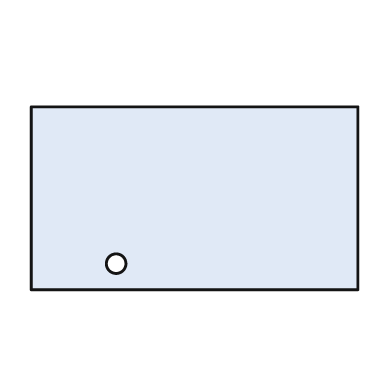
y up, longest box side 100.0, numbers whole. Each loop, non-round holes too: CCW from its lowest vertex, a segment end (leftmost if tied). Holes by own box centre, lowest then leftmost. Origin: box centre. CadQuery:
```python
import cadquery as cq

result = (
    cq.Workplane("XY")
    .moveTo(-50.0, -28.0)
    .lineTo(50.0, -28.0)
    .lineTo(50.0, 28.0)
    .lineTo(-50.0, 28.0)
    .close()
    .moveTo(-24.0, -20.0)
    .circle(3.0)
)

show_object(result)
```